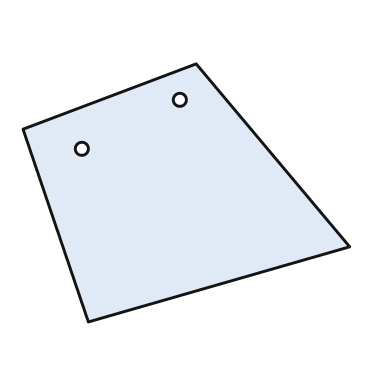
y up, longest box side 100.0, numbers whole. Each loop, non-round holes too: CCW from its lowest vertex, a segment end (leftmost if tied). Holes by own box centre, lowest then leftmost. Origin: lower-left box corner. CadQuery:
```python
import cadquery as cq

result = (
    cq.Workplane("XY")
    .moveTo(20.0, 0.0)
    .lineTo(100.0, 23.0)
    .lineTo(53.0, 79.0)
    .lineTo(0.0, 59.0)
    .close()
    .moveTo(18.0, 53.0)
    .circle(2.0)
    .moveTo(48.0, 68.0)
    .circle(2.0)
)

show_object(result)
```